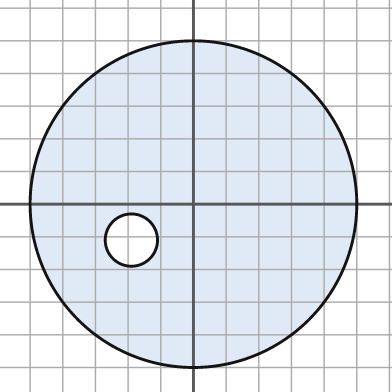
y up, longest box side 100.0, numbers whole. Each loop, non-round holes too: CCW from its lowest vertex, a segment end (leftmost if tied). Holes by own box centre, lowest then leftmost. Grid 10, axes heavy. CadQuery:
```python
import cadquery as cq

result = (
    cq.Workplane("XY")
    .moveTo(0.0, 0.0)
    .circle(50.0)
    .moveTo(-19.0, -11.0)
    .circle(8.0)
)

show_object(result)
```